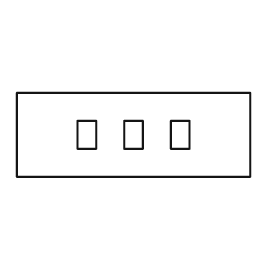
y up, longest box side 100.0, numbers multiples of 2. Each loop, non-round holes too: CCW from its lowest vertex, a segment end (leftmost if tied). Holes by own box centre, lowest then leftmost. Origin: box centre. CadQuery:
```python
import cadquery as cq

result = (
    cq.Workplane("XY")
    .moveTo(-50.0, -18.0)
    .lineTo(50.0, -18.0)
    .lineTo(50.0, 18.0)
    .lineTo(-50.0, 18.0)
    .close()
    .moveTo(-24.0, -6.0)
    .lineTo(-16.0, -6.0)
    .lineTo(-16.0, 6.0)
    .lineTo(-24.0, 6.0)
    .close()
    .moveTo(-4.0, -6.0)
    .lineTo(4.0, -6.0)
    .lineTo(4.0, 6.0)
    .lineTo(-4.0, 6.0)
    .close()
    .moveTo(16.0, -6.0)
    .lineTo(24.0, -6.0)
    .lineTo(24.0, 6.0)
    .lineTo(16.0, 6.0)
    .close()
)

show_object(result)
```